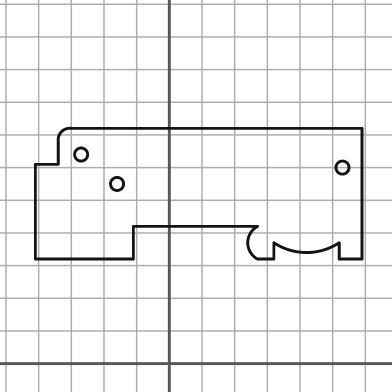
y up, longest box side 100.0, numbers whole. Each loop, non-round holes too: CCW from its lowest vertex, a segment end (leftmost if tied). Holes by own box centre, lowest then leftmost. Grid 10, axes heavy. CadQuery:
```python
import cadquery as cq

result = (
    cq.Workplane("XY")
    .moveTo(-41.0, 32.0)
    .lineTo(-11.0, 32.0)
    .lineTo(-11.0, 42.0)
    .lineTo(27.0, 42.0)
    .threePointArc((24.0, 37.0), (27.0, 32.0))
    .lineTo(32.0, 32.0)
    .lineTo(32.0, 37.0)
    .threePointArc((42.0, 34.0), (52.0, 37.0))
    .lineTo(52.0, 32.0)
    .lineTo(59.0, 32.0)
    .lineTo(59.0, 72.0)
    .lineTo(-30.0, 72.0)
    .threePointArc((-33.0, 71.0), (-34.0, 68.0))
    .lineTo(-34.0, 61.0)
    .lineTo(-41.0, 61.0)
    .close()
    .moveTo(-16.0, 55.0)
    .circle(2.0)
    .moveTo(53.0, 60.0)
    .circle(2.0)
    .moveTo(-27.0, 64.0)
    .circle(2.0)
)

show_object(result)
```